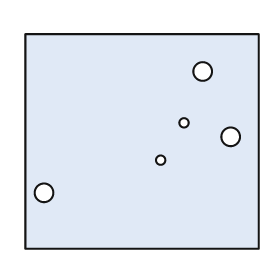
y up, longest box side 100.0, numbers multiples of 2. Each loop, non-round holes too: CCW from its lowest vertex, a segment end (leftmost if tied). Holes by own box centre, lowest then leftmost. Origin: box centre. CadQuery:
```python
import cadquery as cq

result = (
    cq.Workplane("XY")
    .moveTo(-50.0, -46.0)
    .lineTo(50.0, -46.0)
    .lineTo(50.0, 46.0)
    .lineTo(-50.0, 46.0)
    .close()
    .moveTo(-42.0, -22.0)
    .circle(4.0)
    .moveTo(8.0, -8.0)
    .circle(2.0)
    .moveTo(38.0, 2.0)
    .circle(4.0)
    .moveTo(18.0, 8.0)
    .circle(2.0)
    .moveTo(26.0, 30.0)
    .circle(4.0)
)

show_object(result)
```